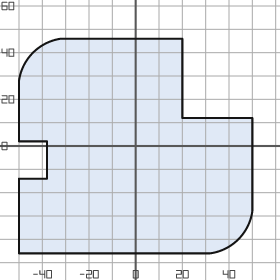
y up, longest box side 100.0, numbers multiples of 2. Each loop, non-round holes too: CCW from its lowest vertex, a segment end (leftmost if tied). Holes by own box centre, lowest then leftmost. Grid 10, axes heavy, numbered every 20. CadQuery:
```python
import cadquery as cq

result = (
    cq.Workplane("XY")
    .moveTo(-50.0, -46.0)
    .lineTo(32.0, -46.0)
    .threePointArc((44.0, -40.0), (50.0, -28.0))
    .lineTo(50.0, 12.0)
    .lineTo(20.0, 12.0)
    .lineTo(20.0, 46.0)
    .lineTo(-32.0, 46.0)
    .threePointArc((-44.0, 40.0), (-50.0, 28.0))
    .lineTo(-50.0, 2.0)
    .lineTo(-38.0, 2.0)
    .lineTo(-38.0, -14.0)
    .lineTo(-50.0, -14.0)
    .close()
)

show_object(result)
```